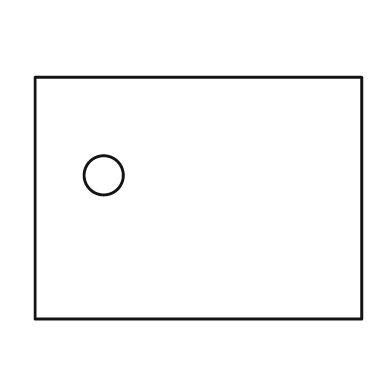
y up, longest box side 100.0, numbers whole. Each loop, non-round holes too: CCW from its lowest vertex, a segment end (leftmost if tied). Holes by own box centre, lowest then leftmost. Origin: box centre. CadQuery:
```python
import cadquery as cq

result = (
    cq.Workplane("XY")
    .moveTo(-50.0, -37.0)
    .lineTo(50.0, -37.0)
    .lineTo(50.0, 37.0)
    .lineTo(-50.0, 37.0)
    .close()
    .moveTo(-29.0, 7.0)
    .circle(6.0)
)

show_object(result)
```